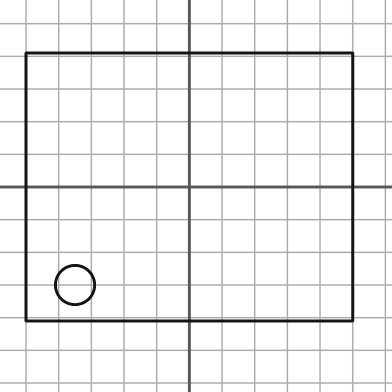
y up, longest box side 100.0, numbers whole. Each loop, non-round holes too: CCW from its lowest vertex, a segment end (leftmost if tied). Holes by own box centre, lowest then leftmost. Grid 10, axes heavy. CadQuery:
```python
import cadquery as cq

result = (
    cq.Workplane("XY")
    .moveTo(-50.0, -41.0)
    .lineTo(50.0, -41.0)
    .lineTo(50.0, 41.0)
    .lineTo(-50.0, 41.0)
    .close()
    .moveTo(-35.0, -30.0)
    .circle(6.0)
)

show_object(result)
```